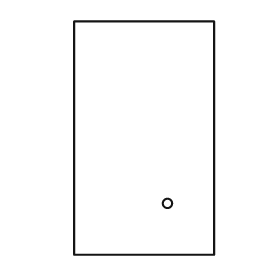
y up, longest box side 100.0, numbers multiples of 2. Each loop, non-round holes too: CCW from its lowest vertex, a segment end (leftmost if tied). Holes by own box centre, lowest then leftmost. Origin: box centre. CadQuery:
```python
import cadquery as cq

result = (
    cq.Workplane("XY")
    .moveTo(-30.0, -50.0)
    .lineTo(30.0, -50.0)
    .lineTo(30.0, 50.0)
    .lineTo(-30.0, 50.0)
    .close()
    .moveTo(10.0, -28.0)
    .circle(2.0)
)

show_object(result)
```